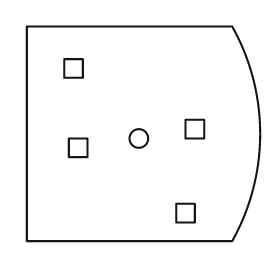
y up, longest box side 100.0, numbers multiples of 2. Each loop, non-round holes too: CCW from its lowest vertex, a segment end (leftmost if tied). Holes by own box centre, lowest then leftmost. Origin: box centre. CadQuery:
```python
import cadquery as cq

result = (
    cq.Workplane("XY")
    .moveTo(-50.0, -46.0)
    .lineTo(38.0, -46.0)
    .threePointArc((50.0, 0.0), (38.0, 46.0))
    .lineTo(-50.0, 46.0)
    .close()
    .moveTo(14.0, -38.0)
    .lineTo(22.0, -38.0)
    .lineTo(22.0, -30.0)
    .lineTo(14.0, -30.0)
    .close()
    .moveTo(-32.0, -10.0)
    .lineTo(-24.0, -10.0)
    .lineTo(-24.0, -2.0)
    .lineTo(-32.0, -2.0)
    .close()
    .moveTo(-2.0, -2.0)
    .circle(4.0)
    .moveTo(18.0, -2.0)
    .lineTo(26.0, -2.0)
    .lineTo(26.0, 6.0)
    .lineTo(18.0, 6.0)
    .close()
    .moveTo(-34.0, 24.0)
    .lineTo(-26.0, 24.0)
    .lineTo(-26.0, 32.0)
    .lineTo(-34.0, 32.0)
    .close()
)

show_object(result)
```